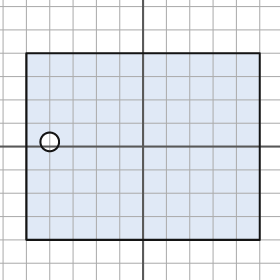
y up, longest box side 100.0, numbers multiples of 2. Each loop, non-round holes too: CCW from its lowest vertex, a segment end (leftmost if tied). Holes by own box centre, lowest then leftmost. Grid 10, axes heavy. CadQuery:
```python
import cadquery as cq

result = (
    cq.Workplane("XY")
    .moveTo(-50.0, -40.0)
    .lineTo(50.0, -40.0)
    .lineTo(50.0, 40.0)
    .lineTo(-50.0, 40.0)
    .close()
    .moveTo(-40.0, 2.0)
    .circle(4.0)
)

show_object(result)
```